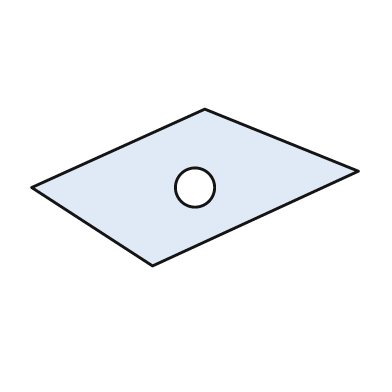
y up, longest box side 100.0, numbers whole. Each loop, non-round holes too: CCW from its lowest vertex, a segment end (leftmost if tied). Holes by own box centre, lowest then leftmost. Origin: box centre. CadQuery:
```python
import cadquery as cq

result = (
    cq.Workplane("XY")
    .moveTo(-13.0, -24.0)
    .lineTo(50.0, 5.0)
    .lineTo(3.0, 24.0)
    .lineTo(-50.0, 0.0)
    .close()
    .moveTo(0.0, 0.0)
    .circle(6.0)
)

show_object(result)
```